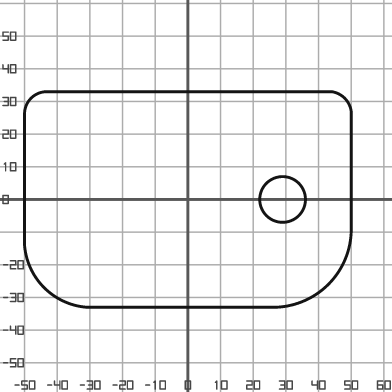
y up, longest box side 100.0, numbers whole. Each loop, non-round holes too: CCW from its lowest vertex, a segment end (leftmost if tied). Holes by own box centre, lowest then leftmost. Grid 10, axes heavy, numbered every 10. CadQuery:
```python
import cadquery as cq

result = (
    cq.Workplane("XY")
    .moveTo(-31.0, -33.0)
    .lineTo(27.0, -33.0)
    .threePointArc((43.0, -26.0), (50.0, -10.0))
    .lineTo(50.0, 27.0)
    .threePointArc((48.0, 31.0), (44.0, 33.0))
    .lineTo(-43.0, 33.0)
    .threePointArc((-48.0, 31.0), (-50.0, 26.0))
    .lineTo(-50.0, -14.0)
    .threePointArc((-44.0, -27.0), (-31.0, -33.0))
    .close()
    .moveTo(29.0, 0.0)
    .circle(7.0)
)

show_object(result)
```